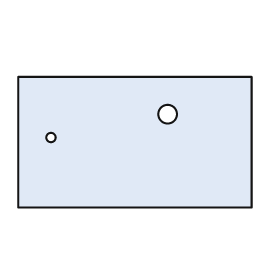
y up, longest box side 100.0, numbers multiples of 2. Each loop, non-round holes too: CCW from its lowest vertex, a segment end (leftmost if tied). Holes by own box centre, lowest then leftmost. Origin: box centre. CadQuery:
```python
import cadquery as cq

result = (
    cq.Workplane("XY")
    .moveTo(-50.0, -28.0)
    .lineTo(50.0, -28.0)
    .lineTo(50.0, 28.0)
    .lineTo(-50.0, 28.0)
    .close()
    .moveTo(-36.0, 2.0)
    .circle(2.0)
    .moveTo(14.0, 12.0)
    .circle(4.0)
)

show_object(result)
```